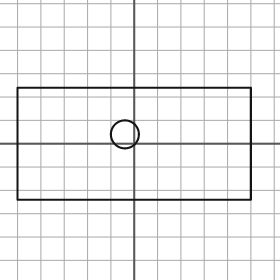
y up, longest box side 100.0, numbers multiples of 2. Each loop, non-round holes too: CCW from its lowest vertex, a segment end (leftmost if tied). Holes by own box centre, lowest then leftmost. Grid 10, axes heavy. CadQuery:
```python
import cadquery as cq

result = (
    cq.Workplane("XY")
    .moveTo(-50.0, -24.0)
    .lineTo(50.0, -24.0)
    .lineTo(50.0, 24.0)
    .lineTo(-50.0, 24.0)
    .close()
    .moveTo(-4.0, 4.0)
    .circle(6.0)
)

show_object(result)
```